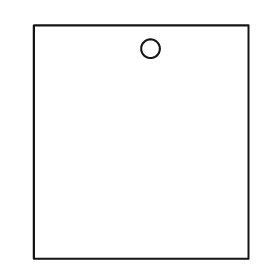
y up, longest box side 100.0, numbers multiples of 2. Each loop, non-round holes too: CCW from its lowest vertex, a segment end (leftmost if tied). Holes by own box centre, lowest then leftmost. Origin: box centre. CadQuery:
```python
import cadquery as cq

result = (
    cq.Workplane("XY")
    .moveTo(-46.0, -50.0)
    .lineTo(46.0, -50.0)
    .lineTo(46.0, 50.0)
    .lineTo(-46.0, 50.0)
    .close()
    .moveTo(4.0, 40.0)
    .circle(4.0)
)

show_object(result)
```